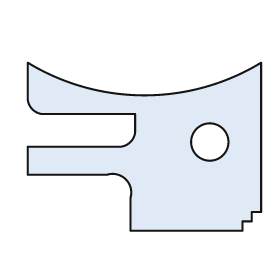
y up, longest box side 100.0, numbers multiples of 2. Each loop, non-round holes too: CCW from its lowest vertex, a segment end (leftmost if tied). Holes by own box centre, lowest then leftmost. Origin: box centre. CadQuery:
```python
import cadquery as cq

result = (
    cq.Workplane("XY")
    .moveTo(-6.0, -36.0)
    .lineTo(42.0, -36.0)
    .lineTo(42.0, -32.0)
    .lineTo(46.0, -32.0)
    .lineTo(46.0, -28.0)
    .lineTo(50.0, -28.0)
    .lineTo(50.0, 36.0)
    .threePointArc((0.0, 22.0), (-50.0, 36.0))
    .lineTo(-50.0, 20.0)
    .threePointArc((-48.0, 16.0), (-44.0, 14.0))
    .lineTo(-4.0, 14.0)
    .lineTo(-4.0, 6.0)
    .threePointArc((-6.0, 2.0), (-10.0, 0.0))
    .lineTo(-50.0, 0.0)
    .lineTo(-50.0, -12.0)
    .lineTo(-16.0, -12.0)
    .threePointArc((-8.0, -14.0), (-6.0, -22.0))
    .close()
    .moveTo(28.0, 2.0)
    .circle(8.0)
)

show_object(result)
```